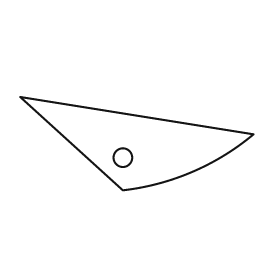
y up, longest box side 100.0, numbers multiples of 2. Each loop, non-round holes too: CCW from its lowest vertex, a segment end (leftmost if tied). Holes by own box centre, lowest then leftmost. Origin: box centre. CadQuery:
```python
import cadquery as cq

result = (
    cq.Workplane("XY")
    .moveTo(-6.0, -20.0)
    .threePointArc((24.0, -12.0), (50.0, 4.0))
    .lineTo(-50.0, 20.0)
    .close()
    .moveTo(-6.0, -6.0)
    .circle(4.0)
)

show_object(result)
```